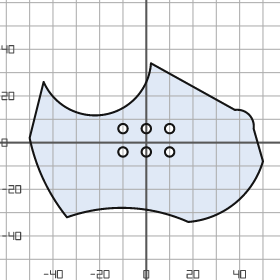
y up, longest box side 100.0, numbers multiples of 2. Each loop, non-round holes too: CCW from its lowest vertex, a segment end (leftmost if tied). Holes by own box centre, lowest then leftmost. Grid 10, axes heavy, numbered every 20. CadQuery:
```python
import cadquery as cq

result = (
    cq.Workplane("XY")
    .moveTo(18.0, -34.0)
    .threePointArc((38.0, -26.0), (50.0, -8.0))
    .lineTo(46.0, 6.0)
    .threePointArc((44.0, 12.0), (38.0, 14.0))
    .lineTo(2.0, 34.0)
    .threePointArc((-18.0, 12.0), (-44.0, 26.0))
    .lineTo(-50.0, 2.0)
    .threePointArc((-44.0, -16.0), (-34.0, -32.0))
    .threePointArc((-8.0, -28.0), (18.0, -34.0))
    .close()
    .moveTo(-10.0, -4.0)
    .circle(2.0)
    .moveTo(0.0, -4.0)
    .circle(2.0)
    .moveTo(10.0, -4.0)
    .circle(2.0)
    .moveTo(-10.0, 6.0)
    .circle(2.0)
    .moveTo(0.0, 6.0)
    .circle(2.0)
    .moveTo(10.0, 6.0)
    .circle(2.0)
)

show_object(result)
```